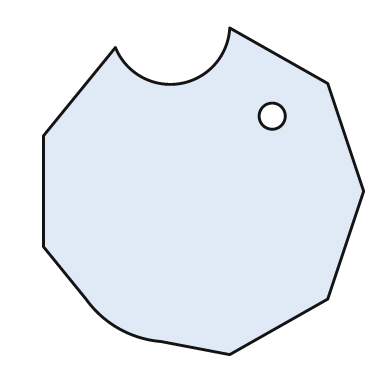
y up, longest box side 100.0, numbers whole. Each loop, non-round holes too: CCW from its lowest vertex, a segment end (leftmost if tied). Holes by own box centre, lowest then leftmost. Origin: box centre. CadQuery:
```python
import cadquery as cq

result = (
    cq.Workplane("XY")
    .moveTo(8.0, -50.0)
    .lineTo(38.0, -33.0)
    .lineTo(49.0, 0.0)
    .lineTo(38.0, 33.0)
    .lineTo(8.0, 50.0)
    .threePointArc((-7.0, 33.0), (-27.0, 44.0))
    .lineTo(-49.0, 17.0)
    .lineTo(-49.0, -17.0)
    .lineTo(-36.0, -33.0)
    .threePointArc((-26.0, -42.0), (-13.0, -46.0))
    .close()
    .moveTo(21.0, 23.0)
    .circle(4.0)
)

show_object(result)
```